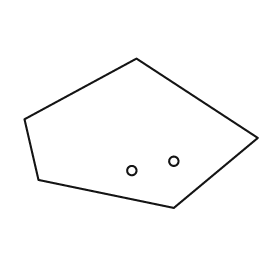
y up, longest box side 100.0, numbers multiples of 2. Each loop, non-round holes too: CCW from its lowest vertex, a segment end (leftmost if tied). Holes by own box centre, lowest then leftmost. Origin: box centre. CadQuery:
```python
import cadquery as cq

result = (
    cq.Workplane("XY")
    .moveTo(14.0, -32.0)
    .lineTo(50.0, -2.0)
    .lineTo(-2.0, 32.0)
    .lineTo(-50.0, 6.0)
    .lineTo(-44.0, -20.0)
    .close()
    .moveTo(-4.0, -16.0)
    .circle(2.0)
    .moveTo(14.0, -12.0)
    .circle(2.0)
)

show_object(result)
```